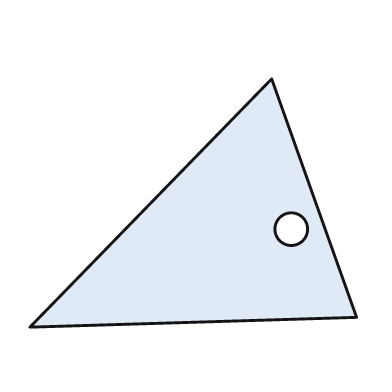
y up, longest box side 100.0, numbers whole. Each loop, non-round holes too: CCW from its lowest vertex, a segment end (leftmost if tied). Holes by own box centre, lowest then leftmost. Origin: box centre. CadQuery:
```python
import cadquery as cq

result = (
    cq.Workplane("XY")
    .moveTo(-50.0, -38.0)
    .lineTo(50.0, -35.0)
    .lineTo(24.0, 38.0)
    .close()
    .moveTo(30.0, -8.0)
    .circle(5.0)
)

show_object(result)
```